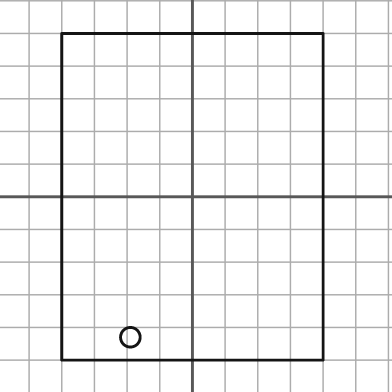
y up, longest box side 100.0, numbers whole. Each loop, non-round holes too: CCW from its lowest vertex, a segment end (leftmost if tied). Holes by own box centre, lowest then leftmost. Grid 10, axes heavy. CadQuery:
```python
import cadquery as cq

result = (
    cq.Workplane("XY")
    .moveTo(-40.0, -50.0)
    .lineTo(40.0, -50.0)
    .lineTo(40.0, 50.0)
    .lineTo(-40.0, 50.0)
    .close()
    .moveTo(-19.0, -43.0)
    .circle(3.0)
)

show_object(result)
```